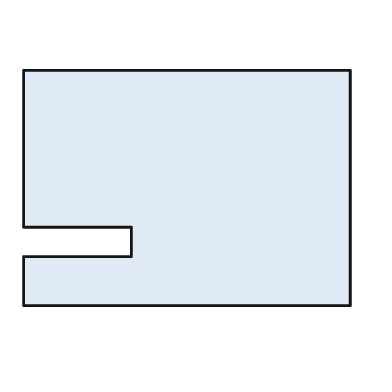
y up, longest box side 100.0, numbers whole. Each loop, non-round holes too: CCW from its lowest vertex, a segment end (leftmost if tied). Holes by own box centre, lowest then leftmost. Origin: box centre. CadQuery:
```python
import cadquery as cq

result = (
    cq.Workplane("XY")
    .moveTo(-50.0, -36.0)
    .lineTo(50.0, -36.0)
    .lineTo(50.0, 36.0)
    .lineTo(-50.0, 36.0)
    .lineTo(-50.0, -12.0)
    .lineTo(-17.0, -12.0)
    .lineTo(-17.0, -21.0)
    .lineTo(-50.0, -21.0)
    .close()
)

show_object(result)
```